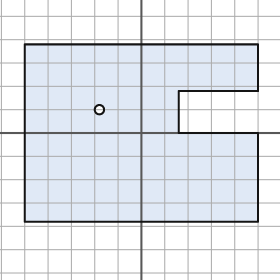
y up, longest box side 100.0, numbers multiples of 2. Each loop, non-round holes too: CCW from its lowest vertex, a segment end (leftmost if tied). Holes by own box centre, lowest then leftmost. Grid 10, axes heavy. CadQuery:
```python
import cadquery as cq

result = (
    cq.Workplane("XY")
    .moveTo(-50.0, -38.0)
    .lineTo(50.0, -38.0)
    .lineTo(50.0, 0.0)
    .lineTo(16.0, 0.0)
    .lineTo(16.0, 18.0)
    .lineTo(50.0, 18.0)
    .lineTo(50.0, 38.0)
    .lineTo(-50.0, 38.0)
    .close()
    .moveTo(-18.0, 10.0)
    .circle(2.0)
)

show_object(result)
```